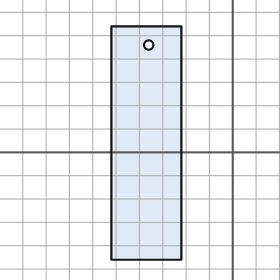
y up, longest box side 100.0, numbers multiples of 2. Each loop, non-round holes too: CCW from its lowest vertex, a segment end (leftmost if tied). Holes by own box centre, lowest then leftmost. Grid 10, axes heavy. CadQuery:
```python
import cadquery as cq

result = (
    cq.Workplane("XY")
    .moveTo(-52.0, -46.0)
    .lineTo(-22.0, -46.0)
    .lineTo(-22.0, 54.0)
    .lineTo(-52.0, 54.0)
    .close()
    .moveTo(-36.0, 46.0)
    .circle(2.0)
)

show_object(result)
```